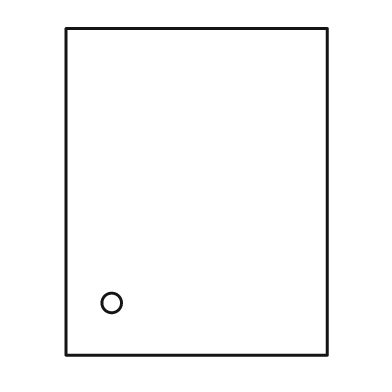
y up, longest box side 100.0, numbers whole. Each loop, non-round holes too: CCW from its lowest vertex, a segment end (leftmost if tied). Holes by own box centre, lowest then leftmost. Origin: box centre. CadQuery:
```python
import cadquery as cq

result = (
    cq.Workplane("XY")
    .moveTo(-40.0, -50.0)
    .lineTo(40.0, -50.0)
    .lineTo(40.0, 50.0)
    .lineTo(-40.0, 50.0)
    .close()
    .moveTo(-26.0, -34.0)
    .circle(3.0)
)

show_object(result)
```